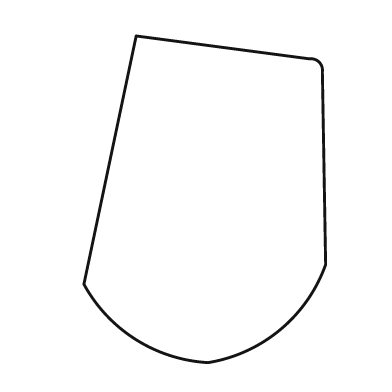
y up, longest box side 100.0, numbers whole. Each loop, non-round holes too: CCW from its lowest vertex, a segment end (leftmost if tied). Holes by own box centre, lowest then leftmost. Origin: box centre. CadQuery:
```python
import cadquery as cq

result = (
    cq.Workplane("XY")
    .moveTo(1.0, -50.0)
    .threePointArc((23.0, -40.0), (37.0, -20.0))
    .lineTo(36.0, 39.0)
    .threePointArc((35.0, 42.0), (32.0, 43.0))
    .lineTo(-21.0, 50.0)
    .lineTo(-37.0, -26.0)
    .threePointArc((-21.0, -43.0), (1.0, -50.0))
    .close()
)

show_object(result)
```